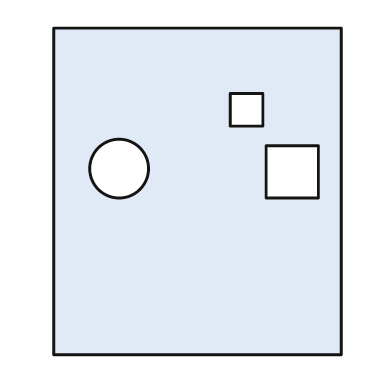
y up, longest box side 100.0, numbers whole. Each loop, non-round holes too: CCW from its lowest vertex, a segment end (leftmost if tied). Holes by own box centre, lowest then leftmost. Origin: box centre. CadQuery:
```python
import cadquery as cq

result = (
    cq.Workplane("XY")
    .moveTo(-44.0, -50.0)
    .lineTo(44.0, -50.0)
    .lineTo(44.0, 50.0)
    .lineTo(-44.0, 50.0)
    .close()
    .moveTo(21.0, -2.0)
    .lineTo(37.0, -2.0)
    .lineTo(37.0, 14.0)
    .lineTo(21.0, 14.0)
    .close()
    .moveTo(-24.0, 7.0)
    .circle(9.0)
    .moveTo(10.0, 20.0)
    .lineTo(20.0, 20.0)
    .lineTo(20.0, 30.0)
    .lineTo(10.0, 30.0)
    .close()
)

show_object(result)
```